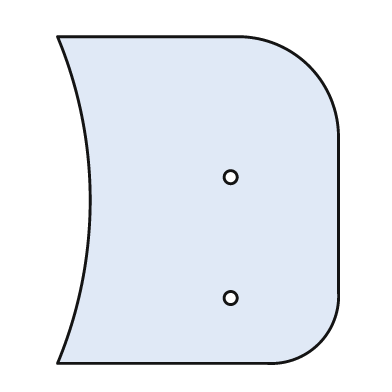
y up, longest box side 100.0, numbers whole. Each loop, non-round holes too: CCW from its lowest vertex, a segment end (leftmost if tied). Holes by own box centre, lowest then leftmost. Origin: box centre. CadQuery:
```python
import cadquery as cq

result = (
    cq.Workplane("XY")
    .moveTo(-43.0, -50.0)
    .lineTo(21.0, -50.0)
    .threePointArc((37.0, -44.0), (43.0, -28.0))
    .lineTo(43.0, 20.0)
    .threePointArc((34.0, 41.0), (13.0, 50.0))
    .lineTo(-43.0, 50.0)
    .threePointArc((-33.0, 0.0), (-43.0, -50.0))
    .close()
    .moveTo(10.0, -30.0)
    .circle(2.0)
    .moveTo(10.0, 7.0)
    .circle(2.0)
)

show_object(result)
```